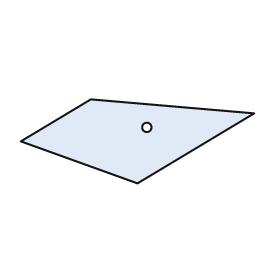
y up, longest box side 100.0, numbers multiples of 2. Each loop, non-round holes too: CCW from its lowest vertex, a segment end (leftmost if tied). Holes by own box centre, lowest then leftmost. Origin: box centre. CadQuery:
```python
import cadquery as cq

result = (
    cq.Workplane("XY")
    .moveTo(0.0, -18.0)
    .lineTo(50.0, 12.0)
    .lineTo(-20.0, 18.0)
    .lineTo(-50.0, 0.0)
    .close()
    .moveTo(4.0, 6.0)
    .circle(2.0)
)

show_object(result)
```